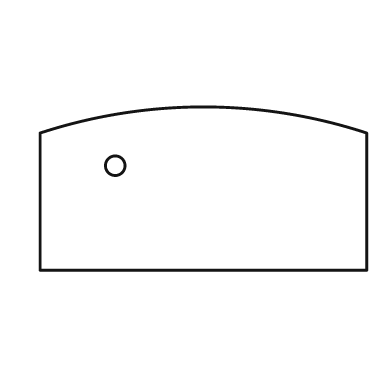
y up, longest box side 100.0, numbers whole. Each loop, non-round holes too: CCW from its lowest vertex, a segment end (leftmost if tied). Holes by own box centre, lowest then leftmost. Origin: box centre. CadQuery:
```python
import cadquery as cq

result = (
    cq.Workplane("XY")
    .moveTo(-50.0, -25.0)
    .lineTo(50.0, -25.0)
    .lineTo(50.0, 17.0)
    .threePointArc((0.0, 25.0), (-50.0, 17.0))
    .close()
    .moveTo(-27.0, 7.0)
    .circle(3.0)
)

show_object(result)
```